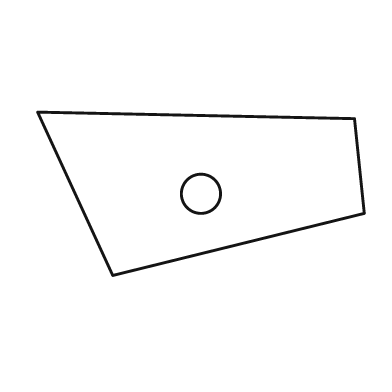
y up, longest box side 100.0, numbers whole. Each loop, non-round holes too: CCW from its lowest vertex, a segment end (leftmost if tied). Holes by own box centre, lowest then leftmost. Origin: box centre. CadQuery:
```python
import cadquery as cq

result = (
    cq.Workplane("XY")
    .moveTo(-27.0, -25.0)
    .lineTo(50.0, -6.0)
    .lineTo(47.0, 23.0)
    .lineTo(-50.0, 25.0)
    .close()
    .moveTo(0.0, 0.0)
    .circle(6.0)
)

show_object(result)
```